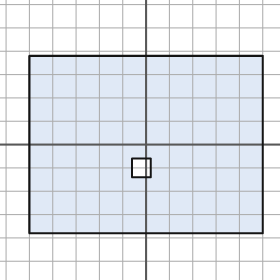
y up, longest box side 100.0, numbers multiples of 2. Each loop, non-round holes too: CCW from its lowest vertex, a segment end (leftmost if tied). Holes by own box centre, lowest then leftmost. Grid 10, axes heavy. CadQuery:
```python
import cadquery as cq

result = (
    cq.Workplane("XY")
    .moveTo(-50.0, -38.0)
    .lineTo(50.0, -38.0)
    .lineTo(50.0, 38.0)
    .lineTo(-50.0, 38.0)
    .close()
    .moveTo(-6.0, -14.0)
    .lineTo(2.0, -14.0)
    .lineTo(2.0, -6.0)
    .lineTo(-6.0, -6.0)
    .close()
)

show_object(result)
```